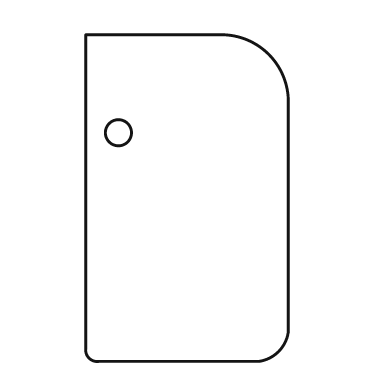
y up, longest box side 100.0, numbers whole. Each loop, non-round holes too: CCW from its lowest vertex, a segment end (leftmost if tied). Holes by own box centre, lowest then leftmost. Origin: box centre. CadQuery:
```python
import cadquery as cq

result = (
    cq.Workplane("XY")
    .moveTo(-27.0, -50.0)
    .lineTo(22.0, -50.0)
    .threePointArc((28.0, -47.0), (31.0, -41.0))
    .lineTo(31.0, 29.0)
    .threePointArc((25.0, 44.0), (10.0, 50.0))
    .lineTo(-31.0, 50.0)
    .lineTo(-31.0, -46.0)
    .threePointArc((-30.0, -49.0), (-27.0, -50.0))
    .close()
    .moveTo(-21.0, 20.0)
    .circle(4.0)
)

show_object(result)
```